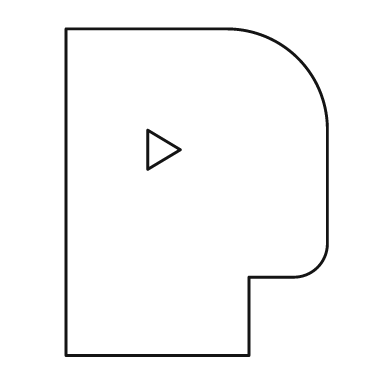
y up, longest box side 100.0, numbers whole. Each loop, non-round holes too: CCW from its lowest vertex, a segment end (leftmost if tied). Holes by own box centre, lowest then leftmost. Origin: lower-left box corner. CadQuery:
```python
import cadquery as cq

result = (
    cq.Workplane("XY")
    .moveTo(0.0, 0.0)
    .lineTo(56.0, 0.0)
    .lineTo(56.0, 24.0)
    .lineTo(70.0, 24.0)
    .threePointArc((77.0, 27.0), (80.0, 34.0))
    .lineTo(80.0, 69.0)
    .threePointArc((71.0, 91.0), (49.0, 100.0))
    .lineTo(0.0, 100.0)
    .close()
    .moveTo(25.0, 57.0)
    .lineTo(35.0, 63.0)
    .lineTo(25.0, 69.0)
    .close()
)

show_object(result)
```